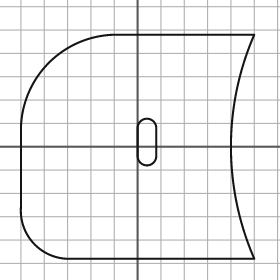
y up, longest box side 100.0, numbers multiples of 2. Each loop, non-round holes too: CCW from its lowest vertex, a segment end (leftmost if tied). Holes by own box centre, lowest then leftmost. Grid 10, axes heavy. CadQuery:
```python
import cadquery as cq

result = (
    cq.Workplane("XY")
    .moveTo(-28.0, -48.0)
    .lineTo(50.0, -48.0)
    .threePointArc((40.0, 0.0), (50.0, 48.0))
    .lineTo(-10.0, 48.0)
    .threePointArc((-38.0, 36.0), (-50.0, 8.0))
    .lineTo(-50.0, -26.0)
    .threePointArc((-44.0, -42.0), (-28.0, -48.0))
    .close()
    .moveTo(0.0, -4.0)
    .threePointArc((4.0, -8.0), (8.0, -4.0))
    .lineTo(8.0, 8.0)
    .threePointArc((4.0, 12.0), (0.0, 8.0))
    .close()
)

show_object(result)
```